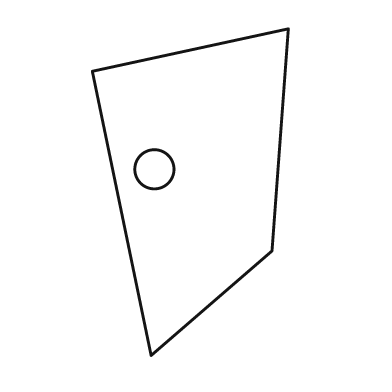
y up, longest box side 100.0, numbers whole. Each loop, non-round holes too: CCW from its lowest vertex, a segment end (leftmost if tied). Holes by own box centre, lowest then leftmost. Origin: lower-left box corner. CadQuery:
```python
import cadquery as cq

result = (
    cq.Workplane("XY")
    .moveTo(18.0, 0.0)
    .lineTo(55.0, 32.0)
    .lineTo(60.0, 100.0)
    .lineTo(0.0, 87.0)
    .close()
    .moveTo(19.0, 57.0)
    .circle(6.0)
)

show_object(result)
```